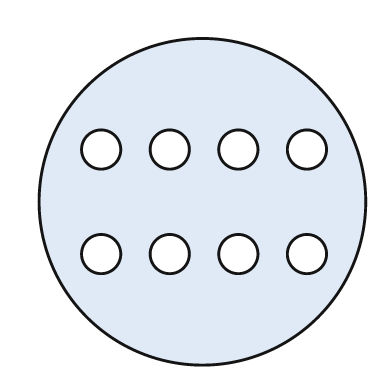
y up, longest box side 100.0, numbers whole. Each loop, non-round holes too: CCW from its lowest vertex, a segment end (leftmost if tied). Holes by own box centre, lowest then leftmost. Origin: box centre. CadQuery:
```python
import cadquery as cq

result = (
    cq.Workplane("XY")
    .moveTo(0.0, 0.0)
    .circle(50.0)
    .moveTo(-31.0, -16.0)
    .circle(6.0)
    .moveTo(-10.0, -16.0)
    .circle(6.0)
    .moveTo(11.0, -16.0)
    .circle(6.0)
    .moveTo(32.0, -16.0)
    .circle(6.0)
    .moveTo(-31.0, 16.0)
    .circle(6.0)
    .moveTo(-10.0, 16.0)
    .circle(6.0)
    .moveTo(11.0, 16.0)
    .circle(6.0)
    .moveTo(32.0, 16.0)
    .circle(6.0)
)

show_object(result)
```